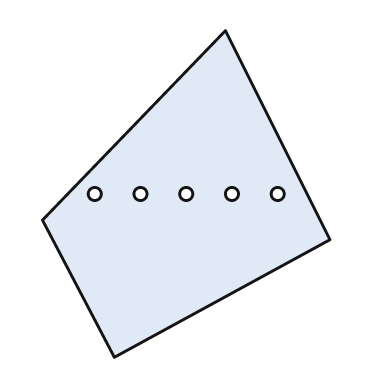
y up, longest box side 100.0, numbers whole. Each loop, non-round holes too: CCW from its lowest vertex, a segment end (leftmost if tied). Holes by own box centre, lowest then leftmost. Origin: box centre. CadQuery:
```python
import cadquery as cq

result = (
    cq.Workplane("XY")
    .moveTo(-22.0, -50.0)
    .lineTo(44.0, -14.0)
    .lineTo(12.0, 50.0)
    .lineTo(-44.0, -8.0)
    .close()
    .moveTo(-28.0, 0.0)
    .circle(2.0)
    .moveTo(-14.0, 0.0)
    .circle(2.0)
    .moveTo(0.0, 0.0)
    .circle(2.0)
    .moveTo(14.0, 0.0)
    .circle(2.0)
    .moveTo(28.0, 0.0)
    .circle(2.0)
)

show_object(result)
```